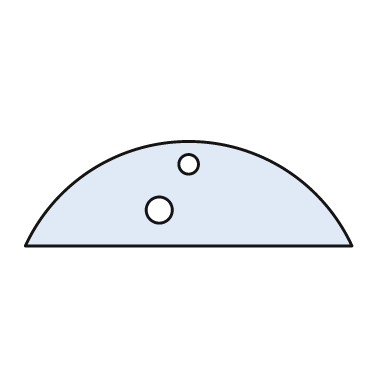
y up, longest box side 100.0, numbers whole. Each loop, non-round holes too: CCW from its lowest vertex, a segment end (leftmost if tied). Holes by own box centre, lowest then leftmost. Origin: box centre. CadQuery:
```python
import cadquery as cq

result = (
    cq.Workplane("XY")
    .moveTo(-50.0, -16.0)
    .lineTo(50.0, -16.0)
    .threePointArc((0.0, 16.0), (-50.0, -16.0))
    .close()
    .moveTo(-9.0, -5.0)
    .circle(4.0)
    .moveTo(0.0, 9.0)
    .circle(3.0)
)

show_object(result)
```